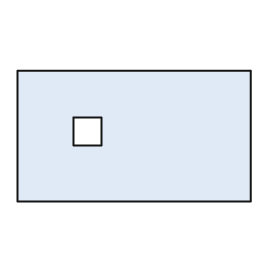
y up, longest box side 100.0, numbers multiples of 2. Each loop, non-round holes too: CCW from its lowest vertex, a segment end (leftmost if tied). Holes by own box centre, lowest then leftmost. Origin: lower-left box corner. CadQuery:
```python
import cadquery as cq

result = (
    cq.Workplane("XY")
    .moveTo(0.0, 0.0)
    .lineTo(100.0, 0.0)
    .lineTo(100.0, 56.0)
    .lineTo(0.0, 56.0)
    .close()
    .moveTo(24.0, 24.0)
    .lineTo(36.0, 24.0)
    .lineTo(36.0, 36.0)
    .lineTo(24.0, 36.0)
    .close()
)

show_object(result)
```